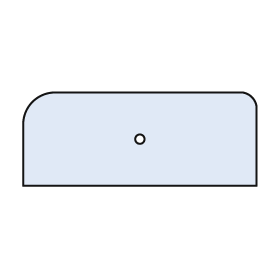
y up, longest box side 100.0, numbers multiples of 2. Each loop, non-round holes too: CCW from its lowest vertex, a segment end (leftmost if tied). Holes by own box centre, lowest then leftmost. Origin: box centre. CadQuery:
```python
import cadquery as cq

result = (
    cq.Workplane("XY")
    .moveTo(-50.0, -20.0)
    .lineTo(50.0, -20.0)
    .lineTo(50.0, 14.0)
    .threePointArc((48.0, 18.0), (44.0, 20.0))
    .lineTo(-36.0, 20.0)
    .threePointArc((-46.0, 16.0), (-50.0, 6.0))
    .close()
    .moveTo(0.0, 0.0)
    .circle(2.0)
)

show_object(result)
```